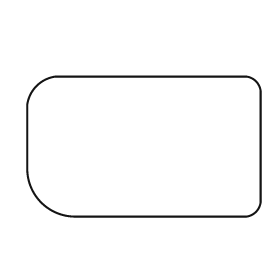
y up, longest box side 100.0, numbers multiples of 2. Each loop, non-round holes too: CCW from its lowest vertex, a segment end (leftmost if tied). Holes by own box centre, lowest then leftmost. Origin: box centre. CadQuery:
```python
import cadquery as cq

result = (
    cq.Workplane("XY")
    .moveTo(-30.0, -30.0)
    .lineTo(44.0, -30.0)
    .threePointArc((48.0, -28.0), (50.0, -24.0))
    .lineTo(50.0, 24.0)
    .threePointArc((48.0, 28.0), (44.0, 30.0))
    .lineTo(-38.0, 30.0)
    .threePointArc((-46.0, 26.0), (-50.0, 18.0))
    .lineTo(-50.0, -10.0)
    .threePointArc((-44.0, -24.0), (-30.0, -30.0))
    .close()
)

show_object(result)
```